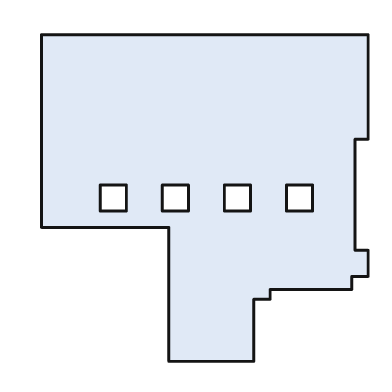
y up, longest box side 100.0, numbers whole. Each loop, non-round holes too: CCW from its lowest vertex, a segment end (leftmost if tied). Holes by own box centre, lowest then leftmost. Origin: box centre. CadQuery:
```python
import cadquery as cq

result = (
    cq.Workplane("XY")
    .moveTo(-11.0, -50.0)
    .lineTo(15.0, -50.0)
    .lineTo(15.0, -31.0)
    .lineTo(20.0, -31.0)
    .lineTo(20.0, -28.0)
    .lineTo(45.0, -28.0)
    .lineTo(45.0, -24.0)
    .lineTo(50.0, -24.0)
    .lineTo(50.0, -16.0)
    .lineTo(46.0, -16.0)
    .lineTo(46.0, 18.0)
    .lineTo(50.0, 18.0)
    .lineTo(50.0, 50.0)
    .lineTo(-50.0, 50.0)
    .lineTo(-50.0, -9.0)
    .lineTo(-11.0, -9.0)
    .close()
    .moveTo(-32.0, -4.0)
    .lineTo(-24.0, -4.0)
    .lineTo(-24.0, 4.0)
    .lineTo(-32.0, 4.0)
    .close()
    .moveTo(-13.0, -4.0)
    .lineTo(-5.0, -4.0)
    .lineTo(-5.0, 4.0)
    .lineTo(-13.0, 4.0)
    .close()
    .moveTo(6.0, -4.0)
    .lineTo(14.0, -4.0)
    .lineTo(14.0, 4.0)
    .lineTo(6.0, 4.0)
    .close()
    .moveTo(25.0, -4.0)
    .lineTo(33.0, -4.0)
    .lineTo(33.0, 4.0)
    .lineTo(25.0, 4.0)
    .close()
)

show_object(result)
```